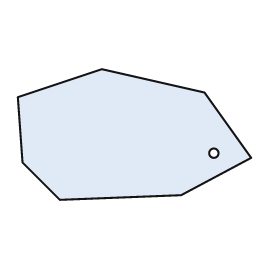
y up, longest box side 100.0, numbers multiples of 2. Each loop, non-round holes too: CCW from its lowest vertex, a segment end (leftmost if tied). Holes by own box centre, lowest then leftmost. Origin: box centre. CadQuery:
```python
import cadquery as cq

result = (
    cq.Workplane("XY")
    .moveTo(-32.0, -28.0)
    .lineTo(20.0, -26.0)
    .lineTo(50.0, -10.0)
    .lineTo(30.0, 18.0)
    .lineTo(-14.0, 28.0)
    .lineTo(-50.0, 16.0)
    .lineTo(-48.0, -12.0)
    .close()
    .moveTo(34.0, -8.0)
    .circle(2.0)
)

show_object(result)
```